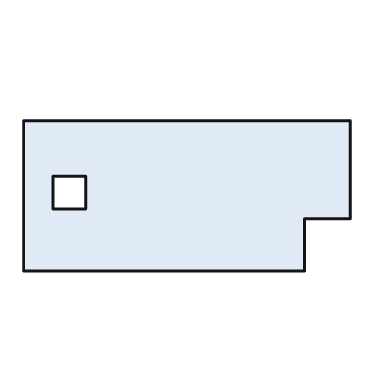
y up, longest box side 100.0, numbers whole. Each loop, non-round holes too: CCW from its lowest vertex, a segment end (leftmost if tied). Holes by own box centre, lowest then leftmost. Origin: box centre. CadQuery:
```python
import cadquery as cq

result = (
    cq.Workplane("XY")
    .moveTo(-50.0, -23.0)
    .lineTo(36.0, -23.0)
    .lineTo(36.0, -7.0)
    .lineTo(50.0, -7.0)
    .lineTo(50.0, 23.0)
    .lineTo(-50.0, 23.0)
    .close()
    .moveTo(-41.0, -4.0)
    .lineTo(-31.0, -4.0)
    .lineTo(-31.0, 6.0)
    .lineTo(-41.0, 6.0)
    .close()
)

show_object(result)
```